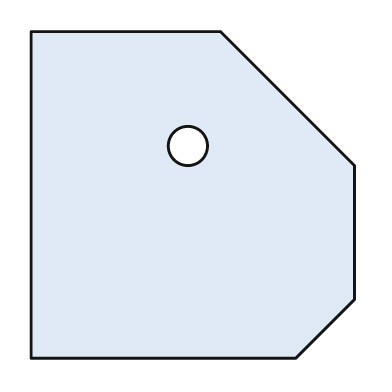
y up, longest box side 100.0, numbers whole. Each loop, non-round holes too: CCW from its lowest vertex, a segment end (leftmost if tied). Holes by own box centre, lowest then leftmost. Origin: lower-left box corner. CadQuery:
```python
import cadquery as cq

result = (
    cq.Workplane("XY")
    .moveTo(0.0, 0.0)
    .lineTo(81.0, 0.0)
    .lineTo(99.0, 18.0)
    .lineTo(99.0, 59.0)
    .lineTo(58.0, 100.0)
    .lineTo(0.0, 100.0)
    .close()
    .moveTo(48.0, 65.0)
    .circle(6.0)
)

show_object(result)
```